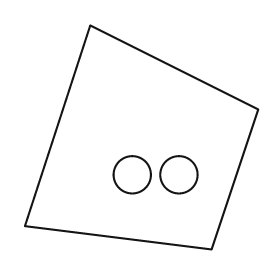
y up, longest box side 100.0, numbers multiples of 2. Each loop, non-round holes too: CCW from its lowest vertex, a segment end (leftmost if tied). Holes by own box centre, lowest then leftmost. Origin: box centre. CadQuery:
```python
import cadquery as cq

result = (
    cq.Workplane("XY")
    .moveTo(30.0, -48.0)
    .lineTo(50.0, 12.0)
    .lineTo(-22.0, 48.0)
    .lineTo(-50.0, -38.0)
    .close()
    .moveTo(-4.0, -16.0)
    .circle(8.0)
    .moveTo(16.0, -16.0)
    .circle(8.0)
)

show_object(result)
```